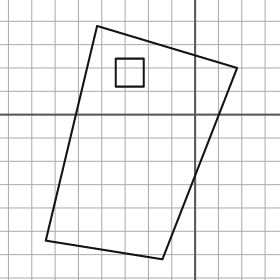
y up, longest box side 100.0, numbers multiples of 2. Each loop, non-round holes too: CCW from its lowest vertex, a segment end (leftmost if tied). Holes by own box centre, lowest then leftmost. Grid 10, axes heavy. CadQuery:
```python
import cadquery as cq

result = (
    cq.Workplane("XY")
    .moveTo(-14.0, -62.0)
    .lineTo(18.0, 20.0)
    .lineTo(-42.0, 38.0)
    .lineTo(-64.0, -54.0)
    .close()
    .moveTo(-34.0, 12.0)
    .lineTo(-22.0, 12.0)
    .lineTo(-22.0, 24.0)
    .lineTo(-34.0, 24.0)
    .close()
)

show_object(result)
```